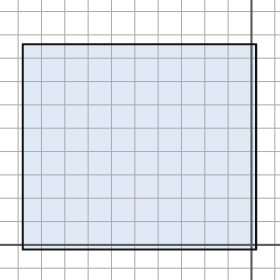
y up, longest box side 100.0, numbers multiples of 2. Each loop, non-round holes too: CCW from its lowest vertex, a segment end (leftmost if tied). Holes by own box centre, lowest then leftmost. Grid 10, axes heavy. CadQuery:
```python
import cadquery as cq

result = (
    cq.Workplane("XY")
    .moveTo(-98.0, -2.0)
    .lineTo(2.0, -2.0)
    .lineTo(2.0, 86.0)
    .lineTo(-98.0, 86.0)
    .close()
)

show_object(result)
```